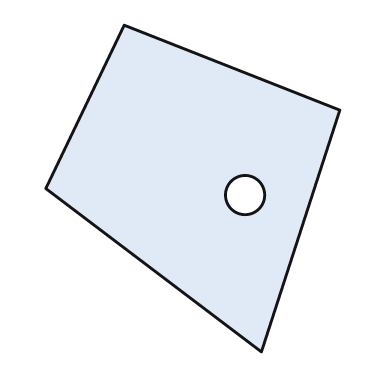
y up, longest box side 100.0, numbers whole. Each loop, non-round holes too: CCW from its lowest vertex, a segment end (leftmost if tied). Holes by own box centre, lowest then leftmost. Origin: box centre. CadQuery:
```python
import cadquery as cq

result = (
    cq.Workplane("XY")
    .moveTo(21.0, -50.0)
    .lineTo(45.0, 24.0)
    .lineTo(-21.0, 50.0)
    .lineTo(-45.0, 0.0)
    .close()
    .moveTo(16.0, -2.0)
    .circle(6.0)
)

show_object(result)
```